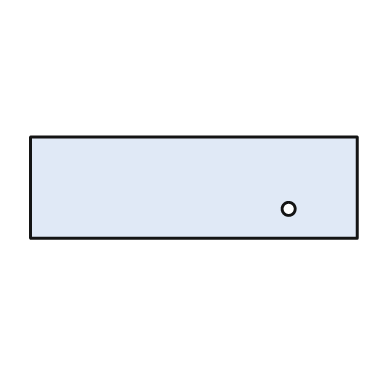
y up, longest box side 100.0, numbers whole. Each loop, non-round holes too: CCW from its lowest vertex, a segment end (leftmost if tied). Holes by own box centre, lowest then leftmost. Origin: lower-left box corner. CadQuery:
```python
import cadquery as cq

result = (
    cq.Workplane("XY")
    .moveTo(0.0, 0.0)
    .lineTo(100.0, 0.0)
    .lineTo(100.0, 31.0)
    .lineTo(0.0, 31.0)
    .close()
    .moveTo(79.0, 9.0)
    .circle(2.0)
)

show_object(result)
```